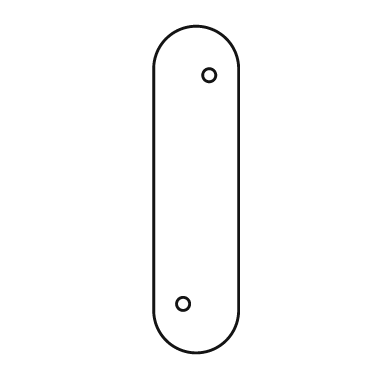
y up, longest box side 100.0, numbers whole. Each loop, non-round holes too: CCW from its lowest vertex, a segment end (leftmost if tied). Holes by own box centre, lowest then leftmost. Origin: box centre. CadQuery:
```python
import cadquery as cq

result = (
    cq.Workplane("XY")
    .moveTo(-13.0, -37.0)
    .threePointArc((0.0, -50.0), (13.0, -37.0))
    .lineTo(13.0, 37.0)
    .threePointArc((0.0, 50.0), (-13.0, 37.0))
    .close()
    .moveTo(-4.0, -35.0)
    .circle(2.0)
    .moveTo(4.0, 35.0)
    .circle(2.0)
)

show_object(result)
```